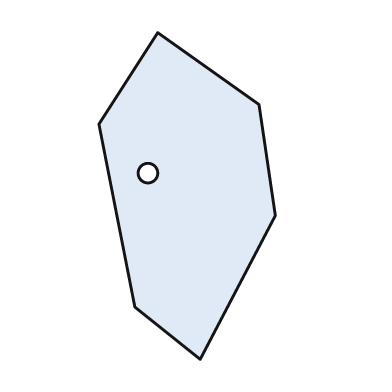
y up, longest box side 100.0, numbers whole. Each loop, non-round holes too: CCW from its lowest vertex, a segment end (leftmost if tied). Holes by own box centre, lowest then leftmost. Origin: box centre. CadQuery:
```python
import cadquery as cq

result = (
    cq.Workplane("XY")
    .moveTo(4.0, -50.0)
    .lineTo(27.0, -6.0)
    .lineTo(22.0, 28.0)
    .lineTo(-9.0, 50.0)
    .lineTo(-27.0, 22.0)
    .lineTo(-16.0, -34.0)
    .close()
    .moveTo(-12.0, 7.0)
    .circle(3.0)
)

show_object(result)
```